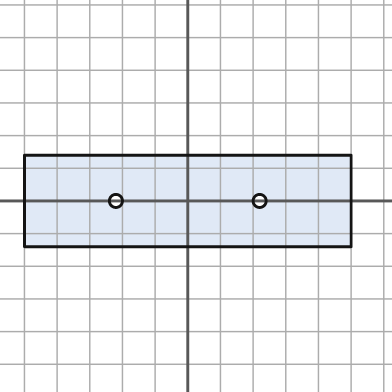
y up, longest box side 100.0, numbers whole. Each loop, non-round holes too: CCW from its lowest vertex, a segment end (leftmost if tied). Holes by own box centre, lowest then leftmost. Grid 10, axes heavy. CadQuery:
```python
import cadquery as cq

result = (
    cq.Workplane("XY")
    .moveTo(-50.0, -14.0)
    .lineTo(50.0, -14.0)
    .lineTo(50.0, 14.0)
    .lineTo(-50.0, 14.0)
    .close()
    .moveTo(-22.0, 0.0)
    .circle(2.0)
    .moveTo(22.0, 0.0)
    .circle(2.0)
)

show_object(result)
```